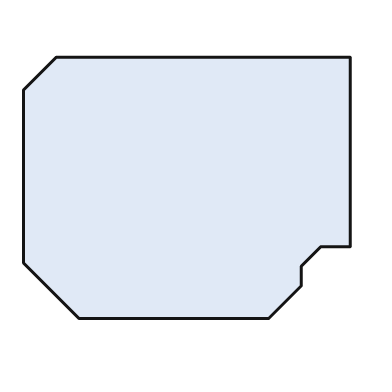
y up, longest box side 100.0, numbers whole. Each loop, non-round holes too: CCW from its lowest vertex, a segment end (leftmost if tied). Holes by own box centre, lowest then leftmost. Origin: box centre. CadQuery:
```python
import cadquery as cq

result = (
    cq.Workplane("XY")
    .moveTo(-33.0, -40.0)
    .lineTo(25.0, -40.0)
    .lineTo(35.0, -30.0)
    .lineTo(35.0, -24.0)
    .lineTo(41.0, -18.0)
    .lineTo(50.0, -18.0)
    .lineTo(50.0, 40.0)
    .lineTo(-40.0, 40.0)
    .lineTo(-50.0, 30.0)
    .lineTo(-50.0, -23.0)
    .close()
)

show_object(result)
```